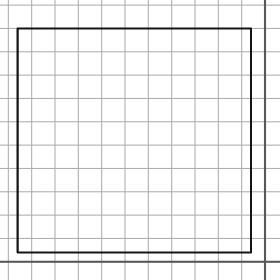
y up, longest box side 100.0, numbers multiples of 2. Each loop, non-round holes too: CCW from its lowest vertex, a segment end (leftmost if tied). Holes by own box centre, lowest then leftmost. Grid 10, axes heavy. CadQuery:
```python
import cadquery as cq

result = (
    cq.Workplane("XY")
    .moveTo(-106.0, 4.0)
    .lineTo(-6.0, 4.0)
    .lineTo(-6.0, 100.0)
    .lineTo(-106.0, 100.0)
    .close()
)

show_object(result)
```